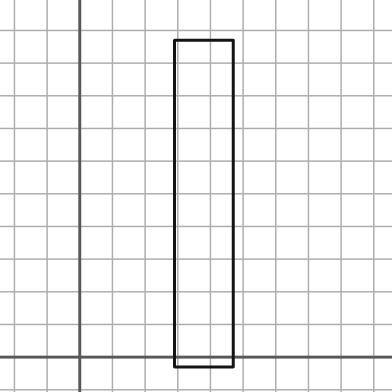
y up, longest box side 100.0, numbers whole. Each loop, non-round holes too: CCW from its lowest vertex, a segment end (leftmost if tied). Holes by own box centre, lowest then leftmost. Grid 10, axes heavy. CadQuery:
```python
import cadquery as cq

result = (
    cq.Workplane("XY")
    .moveTo(29.0, -3.0)
    .lineTo(47.0, -3.0)
    .lineTo(47.0, 97.0)
    .lineTo(29.0, 97.0)
    .close()
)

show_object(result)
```